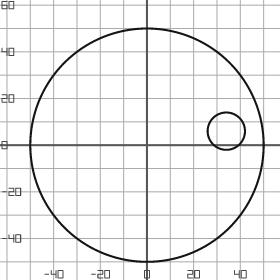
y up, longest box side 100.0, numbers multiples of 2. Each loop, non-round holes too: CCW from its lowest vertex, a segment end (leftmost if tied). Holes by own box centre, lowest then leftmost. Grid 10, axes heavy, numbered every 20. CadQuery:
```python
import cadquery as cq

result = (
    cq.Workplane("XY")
    .moveTo(0.0, 0.0)
    .circle(50.0)
    .moveTo(34.0, 6.0)
    .circle(8.0)
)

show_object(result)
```